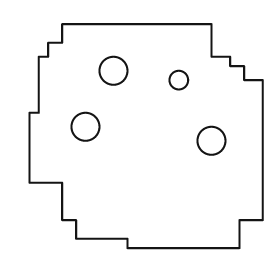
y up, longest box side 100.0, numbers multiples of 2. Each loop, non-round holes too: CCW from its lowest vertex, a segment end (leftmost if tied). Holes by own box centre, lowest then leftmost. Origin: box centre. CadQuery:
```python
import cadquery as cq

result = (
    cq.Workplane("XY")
    .moveTo(-8.0, -48.0)
    .lineTo(40.0, -48.0)
    .lineTo(40.0, -36.0)
    .lineTo(50.0, -36.0)
    .lineTo(50.0, 24.0)
    .lineTo(42.0, 24.0)
    .lineTo(42.0, 30.0)
    .lineTo(36.0, 30.0)
    .lineTo(36.0, 34.0)
    .lineTo(28.0, 34.0)
    .lineTo(28.0, 48.0)
    .lineTo(-36.0, 48.0)
    .lineTo(-36.0, 40.0)
    .lineTo(-42.0, 40.0)
    .lineTo(-42.0, 34.0)
    .lineTo(-46.0, 34.0)
    .lineTo(-46.0, 10.0)
    .lineTo(-50.0, 10.0)
    .lineTo(-50.0, -20.0)
    .lineTo(-36.0, -20.0)
    .lineTo(-36.0, -36.0)
    .lineTo(-30.0, -36.0)
    .lineTo(-30.0, -44.0)
    .lineTo(-8.0, -44.0)
    .close()
    .moveTo(28.0, -2.0)
    .circle(6.0)
    .moveTo(-26.0, 4.0)
    .circle(6.0)
    .moveTo(14.0, 24.0)
    .circle(4.0)
    .moveTo(-14.0, 28.0)
    .circle(6.0)
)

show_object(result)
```